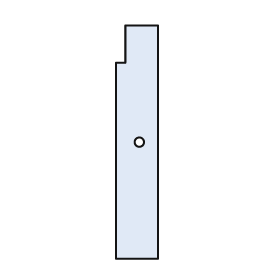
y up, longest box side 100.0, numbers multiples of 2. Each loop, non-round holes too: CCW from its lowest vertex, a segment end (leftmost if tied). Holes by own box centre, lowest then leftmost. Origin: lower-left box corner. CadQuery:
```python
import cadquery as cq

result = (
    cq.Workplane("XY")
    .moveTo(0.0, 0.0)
    .lineTo(18.0, 0.0)
    .lineTo(18.0, 100.0)
    .lineTo(4.0, 100.0)
    .lineTo(4.0, 84.0)
    .lineTo(0.0, 84.0)
    .close()
    .moveTo(10.0, 50.0)
    .circle(2.0)
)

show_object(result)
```